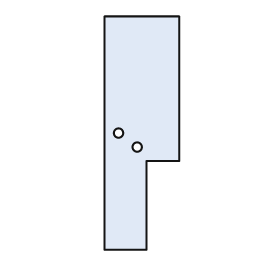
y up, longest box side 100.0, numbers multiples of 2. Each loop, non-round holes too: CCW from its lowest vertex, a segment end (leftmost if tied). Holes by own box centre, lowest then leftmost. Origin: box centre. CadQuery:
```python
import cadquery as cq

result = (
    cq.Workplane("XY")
    .moveTo(-16.0, -50.0)
    .lineTo(2.0, -50.0)
    .lineTo(2.0, -12.0)
    .lineTo(16.0, -12.0)
    .lineTo(16.0, 50.0)
    .lineTo(-16.0, 50.0)
    .close()
    .moveTo(-2.0, -6.0)
    .circle(2.0)
    .moveTo(-10.0, 0.0)
    .circle(2.0)
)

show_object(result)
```